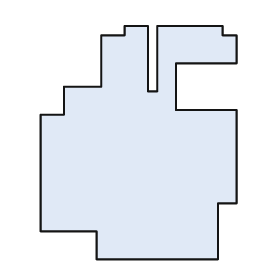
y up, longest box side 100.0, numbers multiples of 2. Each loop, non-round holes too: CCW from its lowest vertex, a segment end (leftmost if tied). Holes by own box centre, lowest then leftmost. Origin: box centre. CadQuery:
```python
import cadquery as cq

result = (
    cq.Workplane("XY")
    .moveTo(-18.0, -50.0)
    .lineTo(34.0, -50.0)
    .lineTo(34.0, -26.0)
    .lineTo(42.0, -26.0)
    .lineTo(42.0, 14.0)
    .lineTo(16.0, 14.0)
    .lineTo(16.0, 34.0)
    .lineTo(42.0, 34.0)
    .lineTo(42.0, 46.0)
    .lineTo(36.0, 46.0)
    .lineTo(36.0, 50.0)
    .lineTo(8.0, 50.0)
    .lineTo(8.0, 22.0)
    .lineTo(4.0, 22.0)
    .lineTo(4.0, 50.0)
    .lineTo(-6.0, 50.0)
    .lineTo(-6.0, 46.0)
    .lineTo(-16.0, 46.0)
    .lineTo(-16.0, 24.0)
    .lineTo(-32.0, 24.0)
    .lineTo(-32.0, 12.0)
    .lineTo(-42.0, 12.0)
    .lineTo(-42.0, -38.0)
    .lineTo(-18.0, -38.0)
    .close()
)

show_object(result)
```